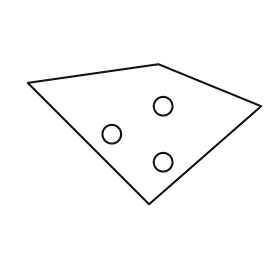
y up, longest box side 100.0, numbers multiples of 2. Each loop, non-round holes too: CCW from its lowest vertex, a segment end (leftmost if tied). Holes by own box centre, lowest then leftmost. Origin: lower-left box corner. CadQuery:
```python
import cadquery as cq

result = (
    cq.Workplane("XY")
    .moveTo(52.0, 0.0)
    .lineTo(100.0, 42.0)
    .lineTo(56.0, 60.0)
    .lineTo(0.0, 52.0)
    .close()
    .moveTo(58.0, 18.0)
    .circle(4.0)
    .moveTo(36.0, 30.0)
    .circle(4.0)
    .moveTo(58.0, 42.0)
    .circle(4.0)
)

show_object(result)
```